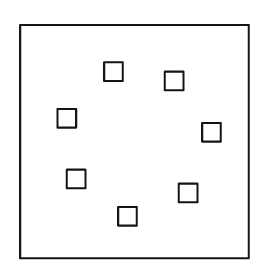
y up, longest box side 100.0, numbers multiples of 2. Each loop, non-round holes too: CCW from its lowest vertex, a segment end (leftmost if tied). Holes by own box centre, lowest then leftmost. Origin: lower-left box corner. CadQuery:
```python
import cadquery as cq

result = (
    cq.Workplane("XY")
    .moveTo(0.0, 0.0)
    .lineTo(98.0, 0.0)
    .lineTo(98.0, 100.0)
    .lineTo(0.0, 100.0)
    .close()
    .moveTo(42.0, 14.0)
    .lineTo(50.0, 14.0)
    .lineTo(50.0, 22.0)
    .lineTo(42.0, 22.0)
    .close()
    .moveTo(68.0, 24.0)
    .lineTo(76.0, 24.0)
    .lineTo(76.0, 32.0)
    .lineTo(68.0, 32.0)
    .close()
    .moveTo(20.0, 30.0)
    .lineTo(28.0, 30.0)
    .lineTo(28.0, 38.0)
    .lineTo(20.0, 38.0)
    .close()
    .moveTo(78.0, 50.0)
    .lineTo(86.0, 50.0)
    .lineTo(86.0, 58.0)
    .lineTo(78.0, 58.0)
    .close()
    .moveTo(16.0, 56.0)
    .lineTo(24.0, 56.0)
    .lineTo(24.0, 64.0)
    .lineTo(16.0, 64.0)
    .close()
    .moveTo(62.0, 72.0)
    .lineTo(70.0, 72.0)
    .lineTo(70.0, 80.0)
    .lineTo(62.0, 80.0)
    .close()
    .moveTo(36.0, 76.0)
    .lineTo(44.0, 76.0)
    .lineTo(44.0, 84.0)
    .lineTo(36.0, 84.0)
    .close()
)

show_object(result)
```